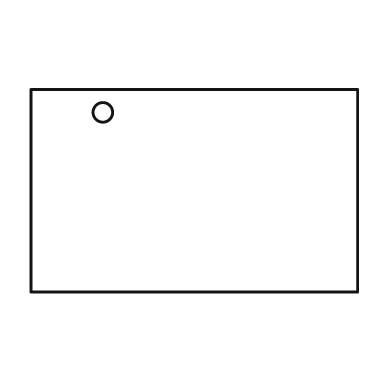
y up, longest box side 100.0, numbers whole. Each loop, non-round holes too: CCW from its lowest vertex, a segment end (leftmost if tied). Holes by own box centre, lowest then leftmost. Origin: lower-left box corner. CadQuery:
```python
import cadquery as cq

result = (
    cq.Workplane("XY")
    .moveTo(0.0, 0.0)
    .lineTo(100.0, 0.0)
    .lineTo(100.0, 62.0)
    .lineTo(0.0, 62.0)
    .close()
    .moveTo(22.0, 55.0)
    .circle(3.0)
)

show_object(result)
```